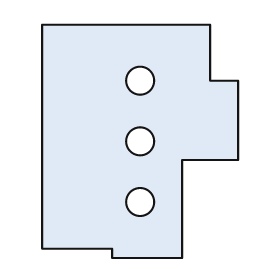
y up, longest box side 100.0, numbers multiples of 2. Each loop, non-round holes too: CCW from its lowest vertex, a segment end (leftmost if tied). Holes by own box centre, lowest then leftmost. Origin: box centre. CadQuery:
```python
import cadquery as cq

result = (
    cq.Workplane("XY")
    .moveTo(-12.0, -50.0)
    .lineTo(18.0, -50.0)
    .lineTo(18.0, -8.0)
    .lineTo(42.0, -8.0)
    .lineTo(42.0, 26.0)
    .lineTo(30.0, 26.0)
    .lineTo(30.0, 50.0)
    .lineTo(-42.0, 50.0)
    .lineTo(-42.0, -46.0)
    .lineTo(-12.0, -46.0)
    .close()
    .moveTo(0.0, -26.0)
    .circle(6.0)
    .moveTo(0.0, 0.0)
    .circle(6.0)
    .moveTo(0.0, 26.0)
    .circle(6.0)
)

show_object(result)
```